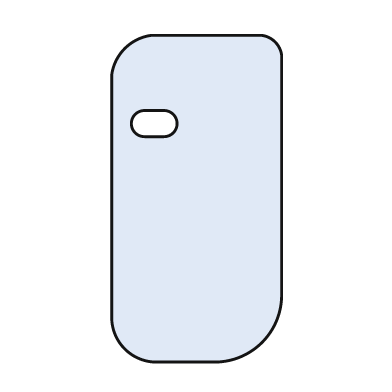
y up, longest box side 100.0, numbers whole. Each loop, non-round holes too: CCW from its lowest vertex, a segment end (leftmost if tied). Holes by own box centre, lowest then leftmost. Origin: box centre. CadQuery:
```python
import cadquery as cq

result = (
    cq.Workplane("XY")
    .moveTo(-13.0, -50.0)
    .lineTo(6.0, -50.0)
    .threePointArc((20.0, -44.0), (26.0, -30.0))
    .lineTo(26.0, 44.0)
    .threePointArc((24.0, 48.0), (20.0, 50.0))
    .lineTo(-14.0, 50.0)
    .threePointArc((-22.0, 46.0), (-26.0, 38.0))
    .lineTo(-26.0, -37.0)
    .threePointArc((-22.0, -46.0), (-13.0, -50.0))
    .close()
    .moveTo(-16.0, 19.0)
    .lineTo(-10.0, 19.0)
    .threePointArc((-6.0, 23.0), (-10.0, 27.0))
    .lineTo(-16.0, 27.0)
    .threePointArc((-20.0, 23.0), (-16.0, 19.0))
    .close()
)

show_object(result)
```